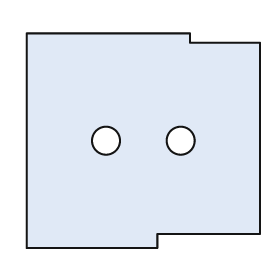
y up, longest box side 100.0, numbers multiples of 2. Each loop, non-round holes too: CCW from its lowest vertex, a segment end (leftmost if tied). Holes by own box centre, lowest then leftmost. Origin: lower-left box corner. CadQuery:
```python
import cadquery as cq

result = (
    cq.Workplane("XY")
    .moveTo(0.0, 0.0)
    .lineTo(56.0, 0.0)
    .lineTo(56.0, 6.0)
    .lineTo(100.0, 6.0)
    .lineTo(100.0, 88.0)
    .lineTo(70.0, 88.0)
    .lineTo(70.0, 92.0)
    .lineTo(0.0, 92.0)
    .close()
    .moveTo(34.0, 46.0)
    .circle(6.0)
    .moveTo(66.0, 46.0)
    .circle(6.0)
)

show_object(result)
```